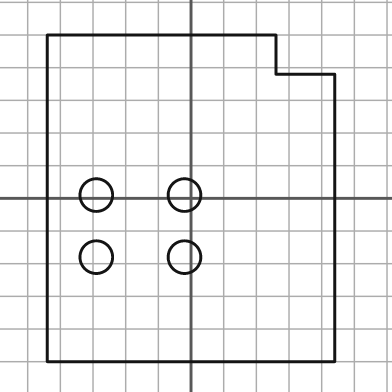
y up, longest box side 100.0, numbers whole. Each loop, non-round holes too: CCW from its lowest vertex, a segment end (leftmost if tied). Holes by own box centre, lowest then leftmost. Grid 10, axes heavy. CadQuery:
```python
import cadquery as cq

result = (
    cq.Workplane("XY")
    .moveTo(-44.0, -50.0)
    .lineTo(44.0, -50.0)
    .lineTo(44.0, 38.0)
    .lineTo(26.0, 38.0)
    .lineTo(26.0, 50.0)
    .lineTo(-44.0, 50.0)
    .close()
    .moveTo(-29.0, -18.0)
    .circle(5.0)
    .moveTo(-2.0, -18.0)
    .circle(5.0)
    .moveTo(-29.0, 1.0)
    .circle(5.0)
    .moveTo(-2.0, 1.0)
    .circle(5.0)
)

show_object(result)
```